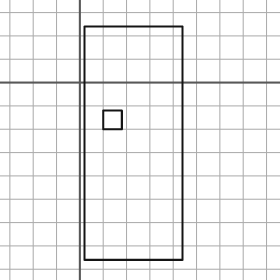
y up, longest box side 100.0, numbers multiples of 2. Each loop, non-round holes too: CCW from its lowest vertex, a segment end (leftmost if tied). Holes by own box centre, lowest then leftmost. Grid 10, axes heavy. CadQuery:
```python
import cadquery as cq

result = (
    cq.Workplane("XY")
    .moveTo(2.0, -76.0)
    .lineTo(44.0, -76.0)
    .lineTo(44.0, 24.0)
    .lineTo(2.0, 24.0)
    .close()
    .moveTo(10.0, -20.0)
    .lineTo(18.0, -20.0)
    .lineTo(18.0, -12.0)
    .lineTo(10.0, -12.0)
    .close()
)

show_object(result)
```